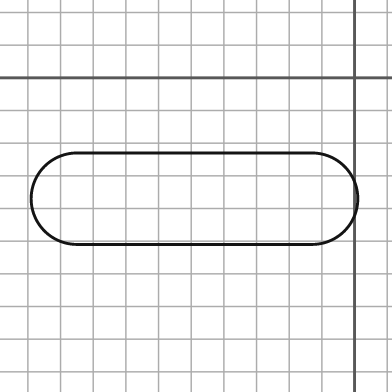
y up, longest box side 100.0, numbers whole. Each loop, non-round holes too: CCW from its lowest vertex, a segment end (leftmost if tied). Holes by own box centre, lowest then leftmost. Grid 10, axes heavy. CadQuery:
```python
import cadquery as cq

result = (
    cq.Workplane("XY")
    .moveTo(-85.0, -51.0)
    .lineTo(-13.0, -51.0)
    .threePointArc((1.0, -37.0), (-13.0, -23.0))
    .lineTo(-85.0, -23.0)
    .threePointArc((-99.0, -37.0), (-85.0, -51.0))
    .close()
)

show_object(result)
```